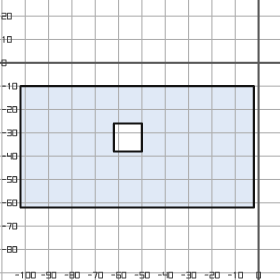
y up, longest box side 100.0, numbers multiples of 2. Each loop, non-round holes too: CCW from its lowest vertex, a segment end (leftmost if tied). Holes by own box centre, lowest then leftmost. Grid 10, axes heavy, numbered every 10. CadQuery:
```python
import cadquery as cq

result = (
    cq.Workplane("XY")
    .moveTo(-102.0, -62.0)
    .lineTo(-2.0, -62.0)
    .lineTo(-2.0, -10.0)
    .lineTo(-102.0, -10.0)
    .close()
    .moveTo(-62.0, -38.0)
    .lineTo(-50.0, -38.0)
    .lineTo(-50.0, -26.0)
    .lineTo(-62.0, -26.0)
    .close()
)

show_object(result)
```